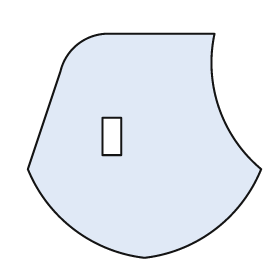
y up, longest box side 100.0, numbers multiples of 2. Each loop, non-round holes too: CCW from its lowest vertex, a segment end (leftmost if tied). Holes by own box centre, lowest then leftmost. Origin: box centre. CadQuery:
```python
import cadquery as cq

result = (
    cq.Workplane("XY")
    .moveTo(0.0, -48.0)
    .threePointArc((30.0, -36.0), (50.0, -10.0))
    .threePointArc((32.0, 16.0), (30.0, 48.0))
    .lineTo(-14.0, 48.0)
    .threePointArc((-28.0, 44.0), (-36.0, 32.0))
    .lineTo(-50.0, -10.0)
    .threePointArc((-30.0, -36.0), (0.0, -48.0))
    .close()
    .moveTo(-18.0, -4.0)
    .lineTo(-10.0, -4.0)
    .lineTo(-10.0, 12.0)
    .lineTo(-18.0, 12.0)
    .close()
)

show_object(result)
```